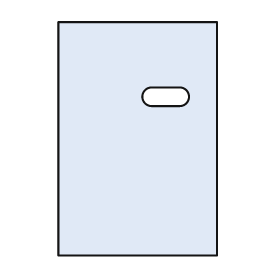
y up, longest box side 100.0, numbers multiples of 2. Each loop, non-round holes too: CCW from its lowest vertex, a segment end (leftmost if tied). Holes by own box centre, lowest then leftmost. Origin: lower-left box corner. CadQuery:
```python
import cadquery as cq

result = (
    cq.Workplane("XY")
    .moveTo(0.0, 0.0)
    .lineTo(68.0, 0.0)
    .lineTo(68.0, 100.0)
    .lineTo(0.0, 100.0)
    .close()
    .moveTo(40.0, 64.0)
    .lineTo(52.0, 64.0)
    .threePointArc((56.0, 68.0), (52.0, 72.0))
    .lineTo(40.0, 72.0)
    .threePointArc((36.0, 68.0), (40.0, 64.0))
    .close()
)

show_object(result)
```